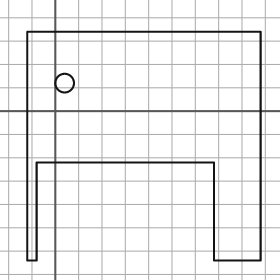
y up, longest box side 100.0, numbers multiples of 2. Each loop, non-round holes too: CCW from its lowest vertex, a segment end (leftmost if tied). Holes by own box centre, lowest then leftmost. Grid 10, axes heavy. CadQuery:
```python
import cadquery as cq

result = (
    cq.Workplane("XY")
    .moveTo(-12.0, -64.0)
    .lineTo(-8.0, -64.0)
    .lineTo(-8.0, -22.0)
    .lineTo(68.0, -22.0)
    .lineTo(68.0, -64.0)
    .lineTo(88.0, -64.0)
    .lineTo(88.0, 34.0)
    .lineTo(-12.0, 34.0)
    .close()
    .moveTo(4.0, 12.0)
    .circle(4.0)
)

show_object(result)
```